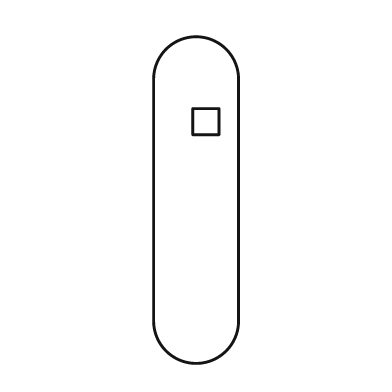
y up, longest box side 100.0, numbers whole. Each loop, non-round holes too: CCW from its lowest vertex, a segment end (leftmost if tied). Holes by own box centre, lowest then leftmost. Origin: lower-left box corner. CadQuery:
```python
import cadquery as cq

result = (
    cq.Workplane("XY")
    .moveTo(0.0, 13.0)
    .threePointArc((13.0, 0.0), (26.0, 13.0))
    .lineTo(26.0, 87.0)
    .threePointArc((13.0, 100.0), (0.0, 87.0))
    .close()
    .moveTo(12.0, 70.0)
    .lineTo(20.0, 70.0)
    .lineTo(20.0, 78.0)
    .lineTo(12.0, 78.0)
    .close()
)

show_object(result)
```